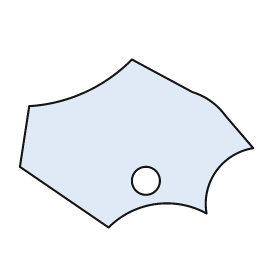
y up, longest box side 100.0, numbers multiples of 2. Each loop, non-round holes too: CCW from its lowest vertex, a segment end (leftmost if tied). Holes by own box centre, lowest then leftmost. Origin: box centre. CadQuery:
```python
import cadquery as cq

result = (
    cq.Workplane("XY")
    .moveTo(-12.0, -36.0)
    .threePointArc((8.0, -26.0), (30.0, -30.0))
    .threePointArc((34.0, -12.0), (50.0, -2.0))
    .lineTo(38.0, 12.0)
    .threePointArc((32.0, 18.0), (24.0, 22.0))
    .lineTo(-2.0, 36.0)
    .threePointArc((-22.0, 22.0), (-46.0, 16.0))
    .lineTo(-50.0, -10.0)
    .close()
    .moveTo(4.0, -16.0)
    .circle(6.0)
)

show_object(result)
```